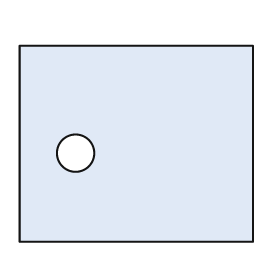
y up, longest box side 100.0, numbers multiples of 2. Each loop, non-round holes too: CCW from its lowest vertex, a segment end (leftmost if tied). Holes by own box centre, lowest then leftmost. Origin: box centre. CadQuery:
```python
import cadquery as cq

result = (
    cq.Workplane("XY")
    .moveTo(-50.0, -42.0)
    .lineTo(50.0, -42.0)
    .lineTo(50.0, 42.0)
    .lineTo(-50.0, 42.0)
    .close()
    .moveTo(-26.0, -4.0)
    .circle(8.0)
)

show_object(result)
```